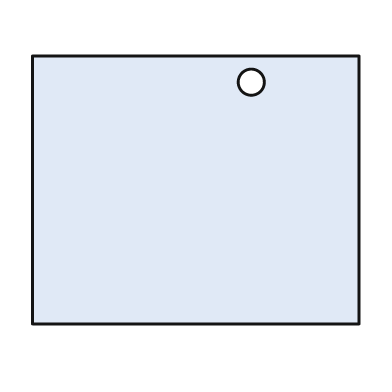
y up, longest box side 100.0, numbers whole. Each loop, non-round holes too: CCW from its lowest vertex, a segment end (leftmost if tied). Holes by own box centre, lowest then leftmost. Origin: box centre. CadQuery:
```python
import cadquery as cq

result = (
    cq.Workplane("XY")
    .moveTo(-50.0, -41.0)
    .lineTo(50.0, -41.0)
    .lineTo(50.0, 41.0)
    .lineTo(-50.0, 41.0)
    .close()
    .moveTo(17.0, 33.0)
    .circle(4.0)
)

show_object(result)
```